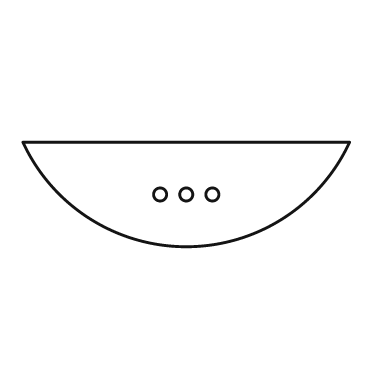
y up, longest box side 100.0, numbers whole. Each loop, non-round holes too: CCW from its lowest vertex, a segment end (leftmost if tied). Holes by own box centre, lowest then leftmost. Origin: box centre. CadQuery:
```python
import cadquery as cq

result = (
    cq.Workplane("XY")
    .moveTo(-50.0, 16.0)
    .threePointArc((0.0, -16.0), (50.0, 16.0))
    .close()
    .moveTo(-8.0, 0.0)
    .circle(2.0)
    .moveTo(0.0, 0.0)
    .circle(2.0)
    .moveTo(8.0, 0.0)
    .circle(2.0)
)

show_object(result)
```